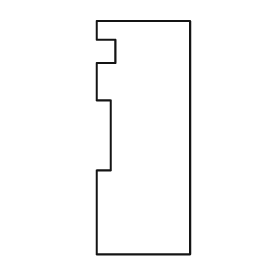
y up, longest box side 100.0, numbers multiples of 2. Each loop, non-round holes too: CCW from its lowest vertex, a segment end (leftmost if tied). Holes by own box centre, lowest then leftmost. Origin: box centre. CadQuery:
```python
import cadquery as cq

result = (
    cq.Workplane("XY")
    .moveTo(-20.0, -50.0)
    .lineTo(20.0, -50.0)
    .lineTo(20.0, 50.0)
    .lineTo(-20.0, 50.0)
    .lineTo(-20.0, 42.0)
    .lineTo(-12.0, 42.0)
    .lineTo(-12.0, 32.0)
    .lineTo(-20.0, 32.0)
    .lineTo(-20.0, 16.0)
    .lineTo(-14.0, 16.0)
    .lineTo(-14.0, -14.0)
    .lineTo(-20.0, -14.0)
    .close()
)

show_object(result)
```